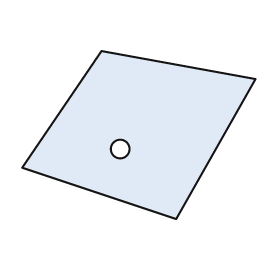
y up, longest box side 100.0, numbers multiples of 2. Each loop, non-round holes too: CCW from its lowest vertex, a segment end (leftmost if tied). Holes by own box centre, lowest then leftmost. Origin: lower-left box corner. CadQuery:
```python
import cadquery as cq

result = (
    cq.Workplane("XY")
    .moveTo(66.0, 0.0)
    .lineTo(100.0, 60.0)
    .lineTo(34.0, 72.0)
    .lineTo(0.0, 22.0)
    .close()
    .moveTo(42.0, 30.0)
    .circle(4.0)
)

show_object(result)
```